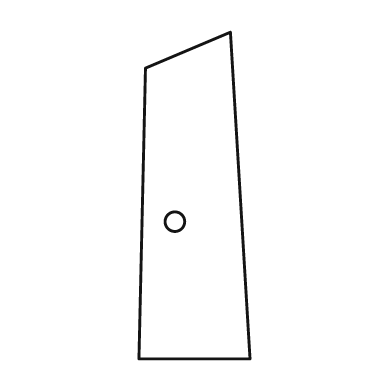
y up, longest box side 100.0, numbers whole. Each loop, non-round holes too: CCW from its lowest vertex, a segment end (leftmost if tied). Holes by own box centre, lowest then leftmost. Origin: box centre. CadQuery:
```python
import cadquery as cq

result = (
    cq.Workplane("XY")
    .moveTo(-17.0, -50.0)
    .lineTo(17.0, -50.0)
    .lineTo(11.0, 50.0)
    .lineTo(-15.0, 39.0)
    .close()
    .moveTo(-6.0, -8.0)
    .circle(3.0)
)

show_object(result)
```